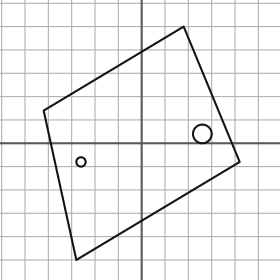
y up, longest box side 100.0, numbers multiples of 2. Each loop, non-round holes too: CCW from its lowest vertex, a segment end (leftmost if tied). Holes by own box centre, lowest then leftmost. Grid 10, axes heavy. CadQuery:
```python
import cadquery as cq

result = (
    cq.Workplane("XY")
    .moveTo(-28.0, -50.0)
    .lineTo(42.0, -8.0)
    .lineTo(18.0, 50.0)
    .lineTo(-42.0, 14.0)
    .close()
    .moveTo(-26.0, -8.0)
    .circle(2.0)
    .moveTo(26.0, 4.0)
    .circle(4.0)
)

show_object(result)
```